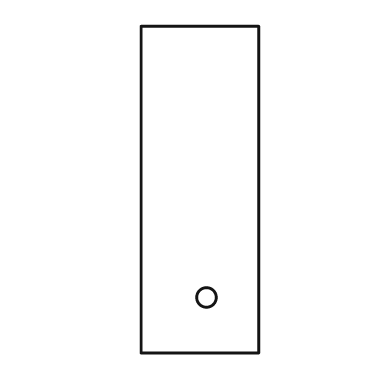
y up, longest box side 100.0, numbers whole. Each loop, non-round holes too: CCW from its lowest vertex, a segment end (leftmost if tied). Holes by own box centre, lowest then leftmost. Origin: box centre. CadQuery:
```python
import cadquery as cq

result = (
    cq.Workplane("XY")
    .moveTo(-18.0, -50.0)
    .lineTo(18.0, -50.0)
    .lineTo(18.0, 50.0)
    .lineTo(-18.0, 50.0)
    .close()
    .moveTo(2.0, -33.0)
    .circle(3.0)
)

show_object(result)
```